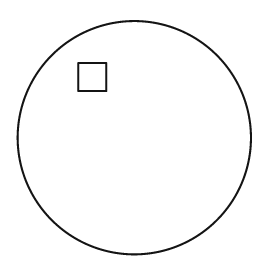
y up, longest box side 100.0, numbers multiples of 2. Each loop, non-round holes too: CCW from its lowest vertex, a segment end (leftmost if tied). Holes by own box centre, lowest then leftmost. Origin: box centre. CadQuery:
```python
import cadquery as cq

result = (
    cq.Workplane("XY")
    .moveTo(0.0, 0.0)
    .circle(50.0)
    .moveTo(-24.0, 20.0)
    .lineTo(-12.0, 20.0)
    .lineTo(-12.0, 32.0)
    .lineTo(-24.0, 32.0)
    .close()
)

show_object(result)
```